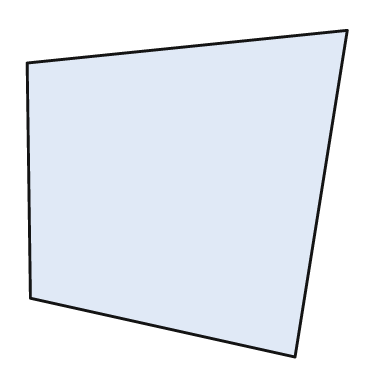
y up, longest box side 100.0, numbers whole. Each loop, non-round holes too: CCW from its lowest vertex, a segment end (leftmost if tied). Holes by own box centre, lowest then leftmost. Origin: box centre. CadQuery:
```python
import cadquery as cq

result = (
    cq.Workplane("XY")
    .moveTo(33.0, -50.0)
    .lineTo(49.0, 50.0)
    .lineTo(-49.0, 40.0)
    .lineTo(-48.0, -32.0)
    .close()
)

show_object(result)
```